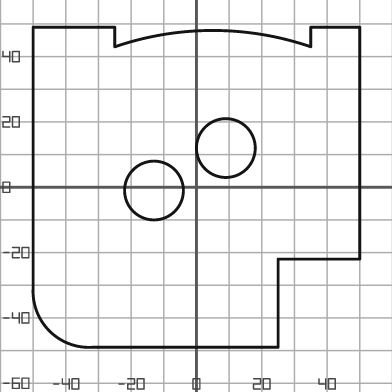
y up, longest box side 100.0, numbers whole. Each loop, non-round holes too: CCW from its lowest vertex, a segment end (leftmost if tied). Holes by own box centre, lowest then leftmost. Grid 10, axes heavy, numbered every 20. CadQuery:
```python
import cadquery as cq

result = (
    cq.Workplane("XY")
    .moveTo(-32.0, -49.0)
    .lineTo(25.0, -49.0)
    .lineTo(25.0, -22.0)
    .lineTo(50.0, -22.0)
    .lineTo(50.0, 49.0)
    .lineTo(35.0, 49.0)
    .lineTo(35.0, 43.0)
    .threePointArc((5.0, 48.0), (-25.0, 43.0))
    .lineTo(-25.0, 49.0)
    .lineTo(-50.0, 49.0)
    .lineTo(-50.0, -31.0)
    .threePointArc((-45.0, -44.0), (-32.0, -49.0))
    .close()
    .moveTo(-13.0, -1.0)
    .circle(9.0)
    .moveTo(9.0, 12.0)
    .circle(9.0)
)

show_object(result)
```